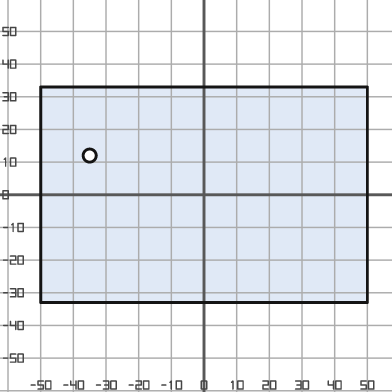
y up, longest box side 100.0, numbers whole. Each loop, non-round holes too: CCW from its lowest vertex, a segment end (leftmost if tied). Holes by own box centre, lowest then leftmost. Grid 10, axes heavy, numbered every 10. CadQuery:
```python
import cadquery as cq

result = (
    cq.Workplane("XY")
    .moveTo(-50.0, -33.0)
    .lineTo(50.0, -33.0)
    .lineTo(50.0, 33.0)
    .lineTo(-50.0, 33.0)
    .close()
    .moveTo(-35.0, 12.0)
    .circle(2.0)
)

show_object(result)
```